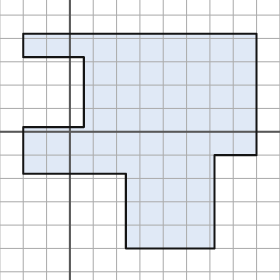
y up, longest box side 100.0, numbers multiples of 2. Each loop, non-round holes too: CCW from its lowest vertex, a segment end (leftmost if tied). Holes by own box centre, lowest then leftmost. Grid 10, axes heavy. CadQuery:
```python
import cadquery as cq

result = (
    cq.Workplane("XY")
    .moveTo(24.0, -50.0)
    .lineTo(62.0, -50.0)
    .lineTo(62.0, -10.0)
    .lineTo(80.0, -10.0)
    .lineTo(80.0, 42.0)
    .lineTo(-20.0, 42.0)
    .lineTo(-20.0, 32.0)
    .lineTo(6.0, 32.0)
    .lineTo(6.0, 2.0)
    .lineTo(-20.0, 2.0)
    .lineTo(-20.0, -18.0)
    .lineTo(24.0, -18.0)
    .close()
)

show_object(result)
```